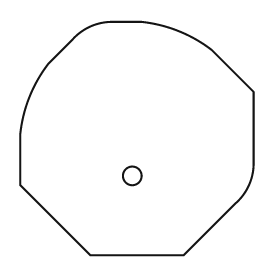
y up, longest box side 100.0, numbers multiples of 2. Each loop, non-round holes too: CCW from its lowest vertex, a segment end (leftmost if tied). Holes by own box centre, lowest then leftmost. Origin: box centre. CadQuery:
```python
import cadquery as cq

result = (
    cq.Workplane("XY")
    .moveTo(-20.0, -50.0)
    .lineTo(20.0, -50.0)
    .lineTo(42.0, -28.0)
    .threePointArc((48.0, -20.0), (50.0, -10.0))
    .lineTo(50.0, 20.0)
    .lineTo(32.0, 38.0)
    .threePointArc((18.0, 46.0), (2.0, 50.0))
    .lineTo(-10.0, 50.0)
    .threePointArc((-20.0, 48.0), (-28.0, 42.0))
    .lineTo(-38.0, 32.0)
    .threePointArc((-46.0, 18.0), (-50.0, 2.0))
    .lineTo(-50.0, -20.0)
    .close()
    .moveTo(-2.0, -16.0)
    .circle(4.0)
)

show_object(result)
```